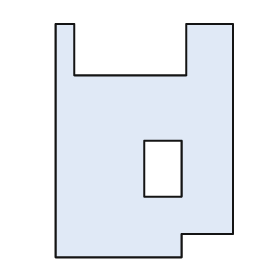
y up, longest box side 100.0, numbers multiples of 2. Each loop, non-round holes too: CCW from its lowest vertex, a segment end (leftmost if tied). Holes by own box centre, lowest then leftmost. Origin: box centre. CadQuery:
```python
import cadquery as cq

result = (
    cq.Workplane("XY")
    .moveTo(-38.0, -50.0)
    .lineTo(16.0, -50.0)
    .lineTo(16.0, -40.0)
    .lineTo(38.0, -40.0)
    .lineTo(38.0, 50.0)
    .lineTo(18.0, 50.0)
    .lineTo(18.0, 28.0)
    .lineTo(-30.0, 28.0)
    .lineTo(-30.0, 50.0)
    .lineTo(-38.0, 50.0)
    .close()
    .moveTo(0.0, -24.0)
    .lineTo(16.0, -24.0)
    .lineTo(16.0, 0.0)
    .lineTo(0.0, 0.0)
    .close()
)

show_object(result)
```